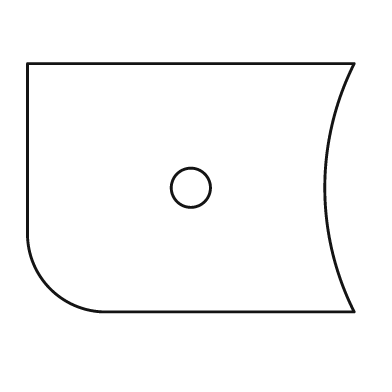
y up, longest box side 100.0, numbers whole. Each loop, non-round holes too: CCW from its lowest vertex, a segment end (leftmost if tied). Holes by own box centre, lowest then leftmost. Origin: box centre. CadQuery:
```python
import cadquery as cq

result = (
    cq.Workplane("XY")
    .moveTo(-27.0, -38.0)
    .lineTo(50.0, -38.0)
    .threePointArc((41.0, 0.0), (50.0, 38.0))
    .lineTo(-50.0, 38.0)
    .lineTo(-50.0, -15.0)
    .threePointArc((-43.0, -31.0), (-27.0, -38.0))
    .close()
    .moveTo(0.0, 0.0)
    .circle(6.0)
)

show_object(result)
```